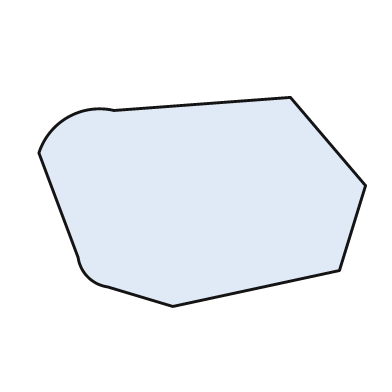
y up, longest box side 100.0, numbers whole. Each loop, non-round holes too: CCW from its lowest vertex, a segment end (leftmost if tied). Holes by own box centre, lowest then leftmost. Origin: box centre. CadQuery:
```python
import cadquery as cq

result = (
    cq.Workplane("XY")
    .moveTo(-9.0, -32.0)
    .lineTo(42.0, -21.0)
    .lineTo(50.0, 5.0)
    .lineTo(27.0, 32.0)
    .lineTo(-27.0, 28.0)
    .threePointArc((-41.0, 26.0), (-50.0, 15.0))
    .lineTo(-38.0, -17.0)
    .threePointArc((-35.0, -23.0), (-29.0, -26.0))
    .close()
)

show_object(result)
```